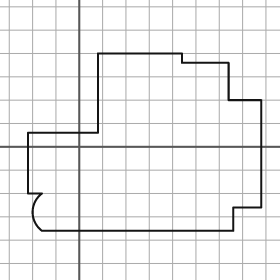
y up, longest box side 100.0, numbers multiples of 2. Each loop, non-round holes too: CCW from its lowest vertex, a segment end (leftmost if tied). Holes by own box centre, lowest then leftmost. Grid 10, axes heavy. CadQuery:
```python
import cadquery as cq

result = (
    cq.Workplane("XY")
    .moveTo(-16.0, -36.0)
    .lineTo(66.0, -36.0)
    .lineTo(66.0, -26.0)
    .lineTo(78.0, -26.0)
    .lineTo(78.0, 20.0)
    .lineTo(64.0, 20.0)
    .lineTo(64.0, 36.0)
    .lineTo(44.0, 36.0)
    .lineTo(44.0, 40.0)
    .lineTo(8.0, 40.0)
    .lineTo(8.0, 6.0)
    .lineTo(-22.0, 6.0)
    .lineTo(-22.0, -20.0)
    .lineTo(-16.0, -20.0)
    .threePointArc((-20.0, -28.0), (-16.0, -36.0))
    .close()
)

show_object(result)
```